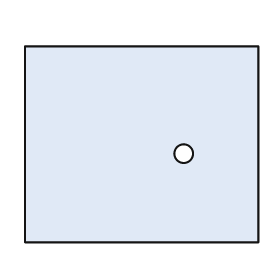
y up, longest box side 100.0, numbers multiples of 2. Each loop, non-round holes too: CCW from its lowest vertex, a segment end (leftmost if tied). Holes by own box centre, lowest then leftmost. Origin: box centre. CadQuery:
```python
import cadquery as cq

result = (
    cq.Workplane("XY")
    .moveTo(-50.0, -42.0)
    .lineTo(50.0, -42.0)
    .lineTo(50.0, 42.0)
    .lineTo(-50.0, 42.0)
    .close()
    .moveTo(18.0, -4.0)
    .circle(4.0)
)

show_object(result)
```